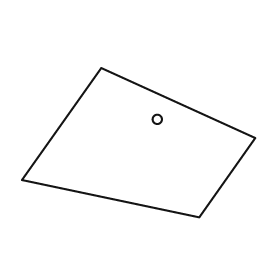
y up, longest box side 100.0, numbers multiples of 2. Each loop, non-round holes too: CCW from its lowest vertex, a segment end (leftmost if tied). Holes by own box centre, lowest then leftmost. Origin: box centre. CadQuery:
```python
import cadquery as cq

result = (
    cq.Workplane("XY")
    .moveTo(26.0, -32.0)
    .lineTo(50.0, 2.0)
    .lineTo(-16.0, 32.0)
    .lineTo(-50.0, -16.0)
    .close()
    .moveTo(8.0, 10.0)
    .circle(2.0)
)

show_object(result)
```